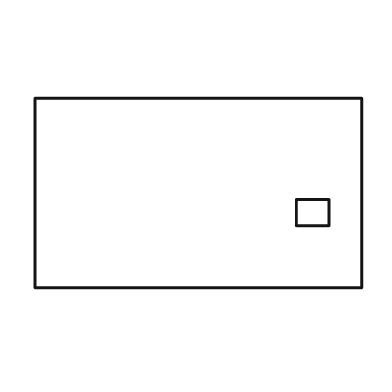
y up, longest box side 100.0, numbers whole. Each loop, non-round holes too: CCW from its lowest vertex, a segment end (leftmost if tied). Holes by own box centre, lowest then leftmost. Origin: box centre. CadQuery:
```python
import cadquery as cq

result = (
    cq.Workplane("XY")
    .moveTo(-50.0, -29.0)
    .lineTo(50.0, -29.0)
    .lineTo(50.0, 29.0)
    .lineTo(-50.0, 29.0)
    .close()
    .moveTo(30.0, -10.0)
    .lineTo(40.0, -10.0)
    .lineTo(40.0, -2.0)
    .lineTo(30.0, -2.0)
    .close()
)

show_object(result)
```